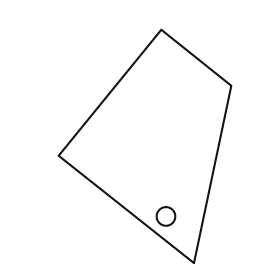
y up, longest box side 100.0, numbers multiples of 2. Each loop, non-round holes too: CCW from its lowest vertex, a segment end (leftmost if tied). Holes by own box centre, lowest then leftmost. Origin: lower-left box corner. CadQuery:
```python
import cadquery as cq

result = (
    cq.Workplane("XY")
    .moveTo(58.0, 0.0)
    .lineTo(74.0, 76.0)
    .lineTo(44.0, 100.0)
    .lineTo(0.0, 46.0)
    .close()
    .moveTo(46.0, 20.0)
    .circle(4.0)
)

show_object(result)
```